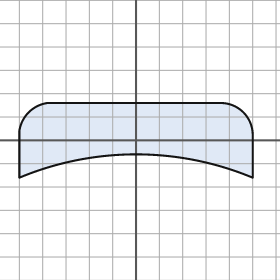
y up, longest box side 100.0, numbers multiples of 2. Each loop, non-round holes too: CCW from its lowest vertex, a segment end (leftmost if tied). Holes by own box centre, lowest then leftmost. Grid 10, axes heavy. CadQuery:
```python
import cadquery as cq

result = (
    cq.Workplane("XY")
    .moveTo(-50.0, -16.0)
    .threePointArc((0.0, -6.0), (50.0, -16.0))
    .lineTo(50.0, 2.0)
    .threePointArc((46.0, 12.0), (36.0, 16.0))
    .lineTo(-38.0, 16.0)
    .threePointArc((-46.0, 12.0), (-50.0, 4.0))
    .close()
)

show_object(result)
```